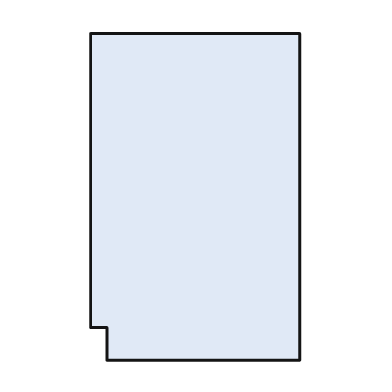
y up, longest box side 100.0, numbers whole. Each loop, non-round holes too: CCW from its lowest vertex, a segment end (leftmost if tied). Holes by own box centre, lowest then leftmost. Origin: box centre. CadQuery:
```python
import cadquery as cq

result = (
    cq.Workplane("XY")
    .moveTo(-27.0, -50.0)
    .lineTo(32.0, -50.0)
    .lineTo(32.0, 50.0)
    .lineTo(-32.0, 50.0)
    .lineTo(-32.0, -40.0)
    .lineTo(-27.0, -40.0)
    .close()
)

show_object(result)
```